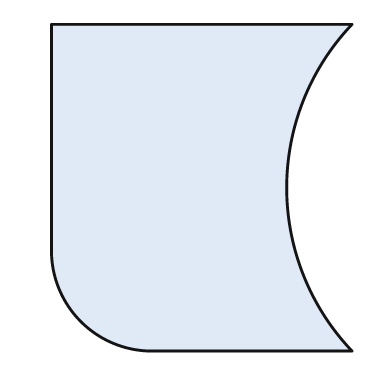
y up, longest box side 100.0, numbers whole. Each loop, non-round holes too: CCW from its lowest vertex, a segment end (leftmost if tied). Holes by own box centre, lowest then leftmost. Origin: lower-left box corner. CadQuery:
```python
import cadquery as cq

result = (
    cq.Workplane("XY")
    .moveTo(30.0, 0.0)
    .lineTo(92.0, 0.0)
    .threePointArc((72.0, 50.0), (92.0, 100.0))
    .lineTo(0.0, 100.0)
    .lineTo(0.0, 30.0)
    .threePointArc((9.0, 9.0), (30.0, 0.0))
    .close()
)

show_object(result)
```